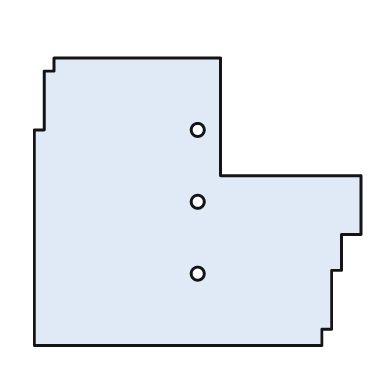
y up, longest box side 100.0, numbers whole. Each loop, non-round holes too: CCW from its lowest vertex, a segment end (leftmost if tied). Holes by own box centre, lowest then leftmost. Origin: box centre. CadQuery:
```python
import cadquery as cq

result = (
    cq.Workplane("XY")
    .moveTo(-50.0, -44.0)
    .lineTo(38.0, -44.0)
    .lineTo(38.0, -39.0)
    .lineTo(41.0, -39.0)
    .lineTo(41.0, -21.0)
    .lineTo(44.0, -21.0)
    .lineTo(44.0, -10.0)
    .lineTo(50.0, -10.0)
    .lineTo(50.0, 8.0)
    .lineTo(7.0, 8.0)
    .lineTo(7.0, 44.0)
    .lineTo(-44.0, 44.0)
    .lineTo(-44.0, 40.0)
    .lineTo(-47.0, 40.0)
    .lineTo(-47.0, 22.0)
    .lineTo(-50.0, 22.0)
    .close()
    .moveTo(0.0, -22.0)
    .circle(2.0)
    .moveTo(0.0, 0.0)
    .circle(2.0)
    .moveTo(0.0, 22.0)
    .circle(2.0)
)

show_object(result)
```